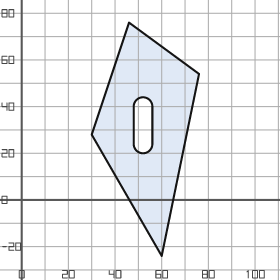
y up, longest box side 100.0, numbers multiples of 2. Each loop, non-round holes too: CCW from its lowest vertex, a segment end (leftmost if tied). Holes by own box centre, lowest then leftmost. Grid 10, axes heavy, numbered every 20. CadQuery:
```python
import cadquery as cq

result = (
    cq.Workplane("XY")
    .moveTo(60.0, -24.0)
    .lineTo(76.0, 54.0)
    .lineTo(46.0, 76.0)
    .lineTo(30.0, 28.0)
    .close()
    .moveTo(48.0, 24.0)
    .threePointArc((52.0, 20.0), (56.0, 24.0))
    .lineTo(56.0, 40.0)
    .threePointArc((52.0, 44.0), (48.0, 40.0))
    .close()
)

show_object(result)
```